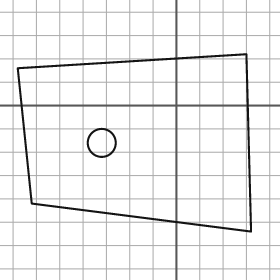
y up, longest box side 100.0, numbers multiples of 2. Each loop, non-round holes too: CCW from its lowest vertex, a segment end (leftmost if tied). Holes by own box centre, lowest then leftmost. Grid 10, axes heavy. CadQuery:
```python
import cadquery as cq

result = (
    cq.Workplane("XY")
    .moveTo(32.0, -54.0)
    .lineTo(30.0, 22.0)
    .lineTo(-68.0, 16.0)
    .lineTo(-62.0, -42.0)
    .close()
    .moveTo(-32.0, -16.0)
    .circle(6.0)
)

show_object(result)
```